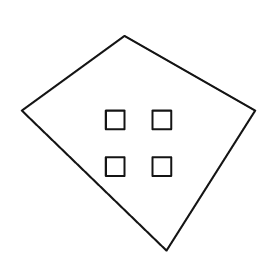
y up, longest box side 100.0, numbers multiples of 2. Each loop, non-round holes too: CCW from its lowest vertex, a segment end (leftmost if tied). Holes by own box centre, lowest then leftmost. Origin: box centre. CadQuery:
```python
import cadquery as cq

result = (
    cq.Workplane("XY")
    .moveTo(12.0, -46.0)
    .lineTo(50.0, 14.0)
    .lineTo(-6.0, 46.0)
    .lineTo(-50.0, 14.0)
    .close()
    .moveTo(-14.0, -14.0)
    .lineTo(-6.0, -14.0)
    .lineTo(-6.0, -6.0)
    .lineTo(-14.0, -6.0)
    .close()
    .moveTo(6.0, -14.0)
    .lineTo(14.0, -14.0)
    .lineTo(14.0, -6.0)
    .lineTo(6.0, -6.0)
    .close()
    .moveTo(-14.0, 6.0)
    .lineTo(-6.0, 6.0)
    .lineTo(-6.0, 14.0)
    .lineTo(-14.0, 14.0)
    .close()
    .moveTo(6.0, 6.0)
    .lineTo(14.0, 6.0)
    .lineTo(14.0, 14.0)
    .lineTo(6.0, 14.0)
    .close()
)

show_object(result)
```